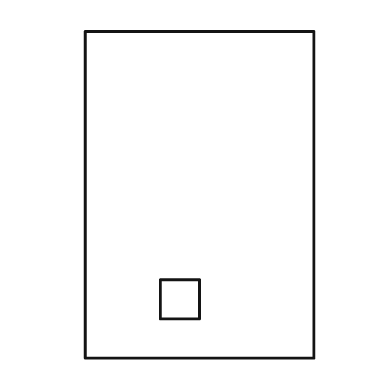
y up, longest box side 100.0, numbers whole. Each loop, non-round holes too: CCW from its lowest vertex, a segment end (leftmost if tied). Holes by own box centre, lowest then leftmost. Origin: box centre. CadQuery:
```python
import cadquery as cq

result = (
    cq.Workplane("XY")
    .moveTo(-35.0, -50.0)
    .lineTo(35.0, -50.0)
    .lineTo(35.0, 50.0)
    .lineTo(-35.0, 50.0)
    .close()
    .moveTo(-12.0, -38.0)
    .lineTo(0.0, -38.0)
    .lineTo(0.0, -26.0)
    .lineTo(-12.0, -26.0)
    .close()
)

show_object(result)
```